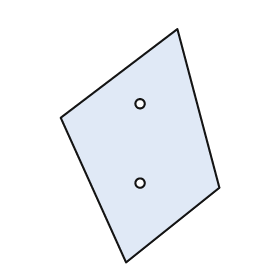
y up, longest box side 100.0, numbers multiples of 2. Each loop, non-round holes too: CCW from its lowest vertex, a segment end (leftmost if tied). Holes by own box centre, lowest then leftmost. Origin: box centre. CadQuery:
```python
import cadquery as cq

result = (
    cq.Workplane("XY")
    .moveTo(-6.0, -50.0)
    .lineTo(34.0, -18.0)
    .lineTo(16.0, 50.0)
    .lineTo(-34.0, 12.0)
    .close()
    .moveTo(0.0, -16.0)
    .circle(2.0)
    .moveTo(0.0, 18.0)
    .circle(2.0)
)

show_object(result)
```